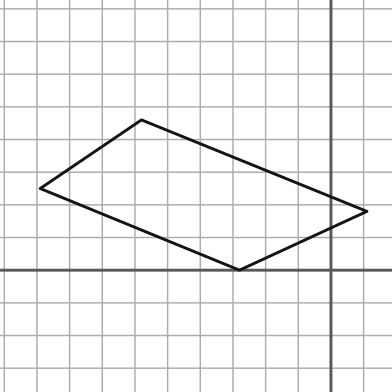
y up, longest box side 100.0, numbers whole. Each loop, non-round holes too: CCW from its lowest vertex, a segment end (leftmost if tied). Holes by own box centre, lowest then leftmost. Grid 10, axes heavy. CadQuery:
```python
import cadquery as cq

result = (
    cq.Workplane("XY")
    .moveTo(-28.0, 0.0)
    .lineTo(11.0, 18.0)
    .lineTo(-58.0, 46.0)
    .lineTo(-89.0, 25.0)
    .close()
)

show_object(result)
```